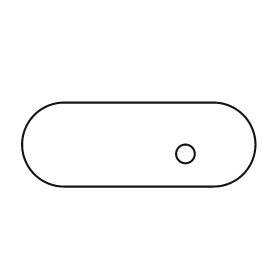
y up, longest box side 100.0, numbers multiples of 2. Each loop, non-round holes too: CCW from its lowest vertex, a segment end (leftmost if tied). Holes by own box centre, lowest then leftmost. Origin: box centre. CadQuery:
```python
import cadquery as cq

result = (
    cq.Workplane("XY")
    .moveTo(-32.0, -18.0)
    .lineTo(32.0, -18.0)
    .threePointArc((50.0, 0.0), (32.0, 18.0))
    .lineTo(-32.0, 18.0)
    .threePointArc((-50.0, 0.0), (-32.0, -18.0))
    .close()
    .moveTo(20.0, -4.0)
    .circle(4.0)
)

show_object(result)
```